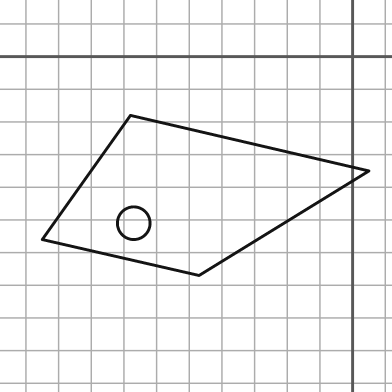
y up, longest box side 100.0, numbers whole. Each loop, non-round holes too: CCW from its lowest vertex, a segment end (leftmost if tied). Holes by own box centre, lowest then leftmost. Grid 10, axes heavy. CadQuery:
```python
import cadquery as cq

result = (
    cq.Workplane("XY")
    .moveTo(-47.0, -67.0)
    .lineTo(5.0, -35.0)
    .lineTo(-68.0, -18.0)
    .lineTo(-95.0, -56.0)
    .close()
    .moveTo(-67.0, -51.0)
    .circle(5.0)
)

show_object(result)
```